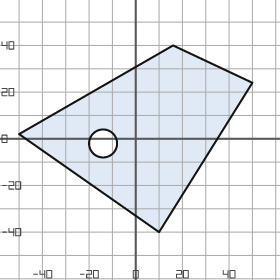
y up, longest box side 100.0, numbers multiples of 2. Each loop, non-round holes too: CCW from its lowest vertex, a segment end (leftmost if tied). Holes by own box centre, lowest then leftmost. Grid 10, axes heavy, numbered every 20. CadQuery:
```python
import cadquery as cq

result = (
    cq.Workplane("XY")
    .moveTo(10.0, -40.0)
    .lineTo(50.0, 24.0)
    .lineTo(16.0, 40.0)
    .lineTo(-50.0, 2.0)
    .close()
    .moveTo(-14.0, -2.0)
    .circle(6.0)
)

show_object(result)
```